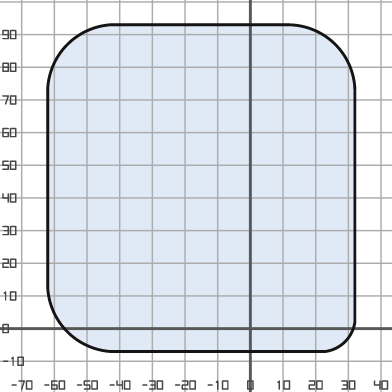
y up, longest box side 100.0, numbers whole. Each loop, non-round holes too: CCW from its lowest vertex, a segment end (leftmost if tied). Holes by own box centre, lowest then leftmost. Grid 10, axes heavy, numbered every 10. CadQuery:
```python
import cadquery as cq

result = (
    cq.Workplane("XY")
    .moveTo(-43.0, -7.0)
    .lineTo(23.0, -7.0)
    .threePointArc((29.0, -4.0), (32.0, 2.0))
    .lineTo(32.0, 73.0)
    .threePointArc((26.0, 87.0), (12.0, 93.0))
    .lineTo(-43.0, 93.0)
    .threePointArc((-56.0, 87.0), (-62.0, 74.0))
    .lineTo(-62.0, 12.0)
    .threePointArc((-56.0, -1.0), (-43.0, -7.0))
    .close()
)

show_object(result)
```